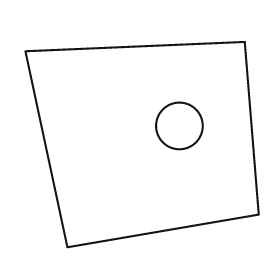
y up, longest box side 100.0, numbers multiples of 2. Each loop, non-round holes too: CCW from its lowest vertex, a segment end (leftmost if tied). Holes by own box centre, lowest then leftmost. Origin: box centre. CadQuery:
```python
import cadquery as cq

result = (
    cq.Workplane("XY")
    .moveTo(-32.0, -44.0)
    .lineTo(50.0, -30.0)
    .lineTo(44.0, 44.0)
    .lineTo(-50.0, 40.0)
    .close()
    .moveTo(16.0, 8.0)
    .circle(10.0)
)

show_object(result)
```